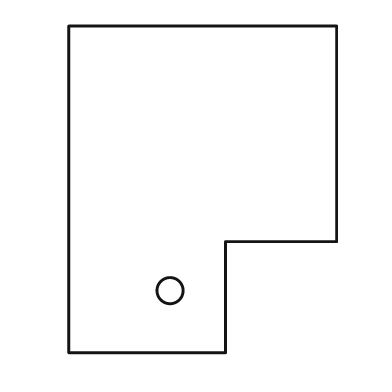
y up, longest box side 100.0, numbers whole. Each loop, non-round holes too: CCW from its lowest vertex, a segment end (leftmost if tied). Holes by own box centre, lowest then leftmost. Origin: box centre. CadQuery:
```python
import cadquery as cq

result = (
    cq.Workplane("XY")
    .moveTo(-41.0, -50.0)
    .lineTo(7.0, -50.0)
    .lineTo(7.0, -16.0)
    .lineTo(41.0, -16.0)
    .lineTo(41.0, 50.0)
    .lineTo(-41.0, 50.0)
    .close()
    .moveTo(-10.0, -31.0)
    .circle(4.0)
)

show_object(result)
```